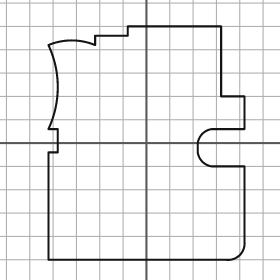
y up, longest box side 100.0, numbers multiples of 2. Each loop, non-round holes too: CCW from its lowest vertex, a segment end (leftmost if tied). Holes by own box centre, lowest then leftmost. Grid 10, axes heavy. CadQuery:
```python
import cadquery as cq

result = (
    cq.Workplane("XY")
    .moveTo(-42.0, -50.0)
    .lineTo(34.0, -50.0)
    .threePointArc((40.0, -48.0), (42.0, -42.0))
    .lineTo(42.0, -10.0)
    .lineTo(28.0, -10.0)
    .threePointArc((24.0, -8.0), (22.0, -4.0))
    .lineTo(22.0, 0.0)
    .threePointArc((24.0, 4.0), (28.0, 6.0))
    .lineTo(42.0, 6.0)
    .lineTo(42.0, 20.0)
    .lineTo(32.0, 20.0)
    .lineTo(32.0, 50.0)
    .lineTo(-8.0, 50.0)
    .lineTo(-8.0, 46.0)
    .lineTo(-22.0, 46.0)
    .lineTo(-22.0, 42.0)
    .threePointArc((-32.0, 44.0), (-42.0, 42.0))
    .threePointArc((-38.0, 24.0), (-42.0, 6.0))
    .lineTo(-38.0, 6.0)
    .lineTo(-38.0, -4.0)
    .lineTo(-42.0, -4.0)
    .close()
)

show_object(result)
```